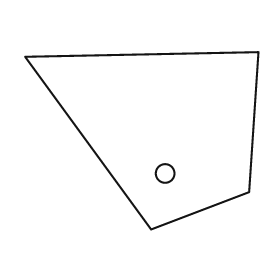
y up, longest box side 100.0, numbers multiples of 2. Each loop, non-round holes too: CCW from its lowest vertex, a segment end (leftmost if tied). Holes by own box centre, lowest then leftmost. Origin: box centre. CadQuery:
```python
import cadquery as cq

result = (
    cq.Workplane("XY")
    .moveTo(4.0, -38.0)
    .lineTo(46.0, -22.0)
    .lineTo(50.0, 38.0)
    .lineTo(-50.0, 36.0)
    .close()
    .moveTo(10.0, -14.0)
    .circle(4.0)
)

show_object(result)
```